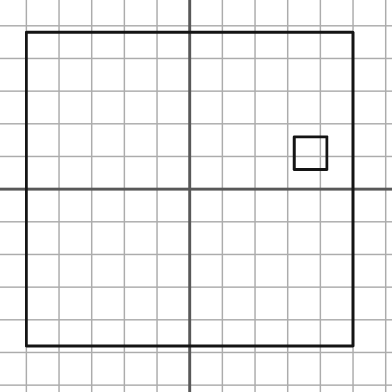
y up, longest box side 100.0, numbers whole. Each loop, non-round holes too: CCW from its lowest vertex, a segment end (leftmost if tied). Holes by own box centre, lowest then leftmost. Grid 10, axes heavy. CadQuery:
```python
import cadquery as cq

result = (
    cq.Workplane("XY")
    .moveTo(-50.0, -48.0)
    .lineTo(50.0, -48.0)
    .lineTo(50.0, 48.0)
    .lineTo(-50.0, 48.0)
    .close()
    .moveTo(32.0, 6.0)
    .lineTo(42.0, 6.0)
    .lineTo(42.0, 16.0)
    .lineTo(32.0, 16.0)
    .close()
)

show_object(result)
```